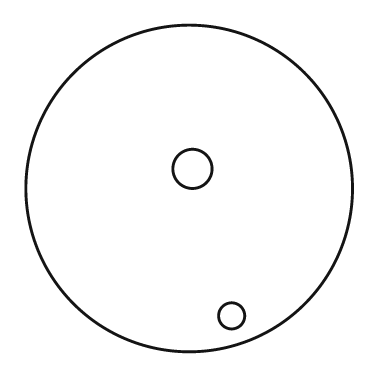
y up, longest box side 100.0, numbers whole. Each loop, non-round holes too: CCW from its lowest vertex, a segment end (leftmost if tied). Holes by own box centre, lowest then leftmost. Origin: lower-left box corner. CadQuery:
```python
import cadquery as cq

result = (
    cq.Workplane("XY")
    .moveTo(50.0, 50.0)
    .circle(50.0)
    .moveTo(63.0, 11.0)
    .circle(4.0)
    .moveTo(51.0, 56.0)
    .circle(6.0)
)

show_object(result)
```